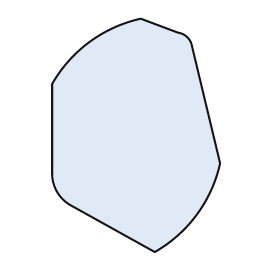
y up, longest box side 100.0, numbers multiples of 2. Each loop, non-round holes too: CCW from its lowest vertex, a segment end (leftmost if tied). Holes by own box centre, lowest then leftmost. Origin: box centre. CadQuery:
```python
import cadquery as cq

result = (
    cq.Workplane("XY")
    .moveTo(8.0, -50.0)
    .threePointArc((26.0, -34.0), (36.0, -12.0))
    .lineTo(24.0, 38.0)
    .threePointArc((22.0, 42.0), (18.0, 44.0))
    .lineTo(2.0, 50.0)
    .threePointArc((-20.0, 40.0), (-36.0, 22.0))
    .lineTo(-36.0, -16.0)
    .threePointArc((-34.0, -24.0), (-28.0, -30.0))
    .close()
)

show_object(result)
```